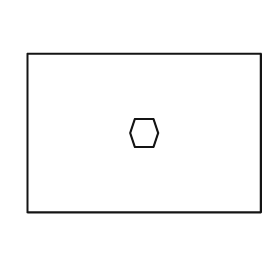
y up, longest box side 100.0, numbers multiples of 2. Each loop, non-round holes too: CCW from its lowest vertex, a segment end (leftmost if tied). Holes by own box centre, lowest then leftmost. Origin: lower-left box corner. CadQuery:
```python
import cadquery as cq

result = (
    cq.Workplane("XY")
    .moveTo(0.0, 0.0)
    .lineTo(100.0, 0.0)
    .lineTo(100.0, 68.0)
    .lineTo(0.0, 68.0)
    .close()
    .moveTo(46.0, 28.0)
    .lineTo(54.0, 28.0)
    .lineTo(56.0, 34.0)
    .lineTo(54.0, 40.0)
    .lineTo(46.0, 40.0)
    .lineTo(44.0, 34.0)
    .close()
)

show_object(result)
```